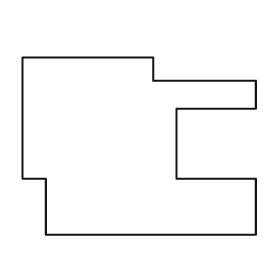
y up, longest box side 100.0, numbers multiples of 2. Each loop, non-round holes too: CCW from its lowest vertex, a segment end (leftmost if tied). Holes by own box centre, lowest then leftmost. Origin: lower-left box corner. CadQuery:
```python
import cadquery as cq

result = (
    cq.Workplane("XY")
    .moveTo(10.0, 0.0)
    .lineTo(100.0, 0.0)
    .lineTo(100.0, 24.0)
    .lineTo(66.0, 24.0)
    .lineTo(66.0, 54.0)
    .lineTo(100.0, 54.0)
    .lineTo(100.0, 66.0)
    .lineTo(56.0, 66.0)
    .lineTo(56.0, 76.0)
    .lineTo(0.0, 76.0)
    .lineTo(0.0, 24.0)
    .lineTo(10.0, 24.0)
    .close()
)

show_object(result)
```